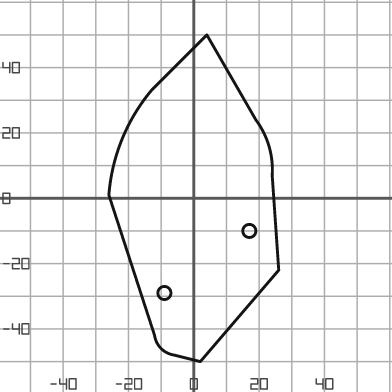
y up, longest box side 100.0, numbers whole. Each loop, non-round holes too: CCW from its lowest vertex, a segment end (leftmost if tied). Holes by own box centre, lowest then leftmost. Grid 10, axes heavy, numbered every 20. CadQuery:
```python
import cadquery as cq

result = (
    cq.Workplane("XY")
    .moveTo(2.0, -50.0)
    .lineTo(26.0, -22.0)
    .lineTo(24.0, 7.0)
    .threePointArc((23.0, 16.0), (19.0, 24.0))
    .lineTo(4.0, 50.0)
    .lineTo(-13.0, 33.0)
    .threePointArc((-22.0, 18.0), (-26.0, 1.0))
    .lineTo(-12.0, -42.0)
    .threePointArc((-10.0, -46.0), (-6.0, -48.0))
    .close()
    .moveTo(-9.0, -29.0)
    .circle(2.0)
    .moveTo(17.0, -10.0)
    .circle(2.0)
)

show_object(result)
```